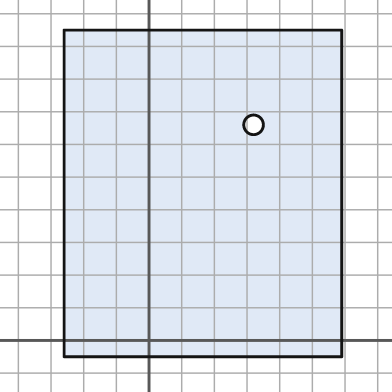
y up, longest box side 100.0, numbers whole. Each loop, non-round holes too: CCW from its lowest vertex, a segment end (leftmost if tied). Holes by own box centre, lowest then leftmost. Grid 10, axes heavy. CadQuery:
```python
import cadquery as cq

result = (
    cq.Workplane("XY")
    .moveTo(-26.0, -5.0)
    .lineTo(59.0, -5.0)
    .lineTo(59.0, 95.0)
    .lineTo(-26.0, 95.0)
    .close()
    .moveTo(32.0, 66.0)
    .circle(3.0)
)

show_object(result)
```